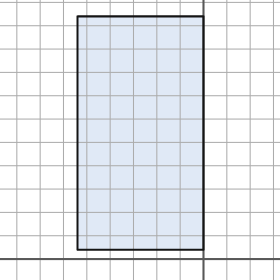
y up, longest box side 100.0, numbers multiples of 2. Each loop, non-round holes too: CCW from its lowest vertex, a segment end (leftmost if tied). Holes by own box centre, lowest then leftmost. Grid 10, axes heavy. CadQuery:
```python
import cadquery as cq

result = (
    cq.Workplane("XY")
    .moveTo(-54.0, 4.0)
    .lineTo(0.0, 4.0)
    .lineTo(0.0, 104.0)
    .lineTo(-54.0, 104.0)
    .close()
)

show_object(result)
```